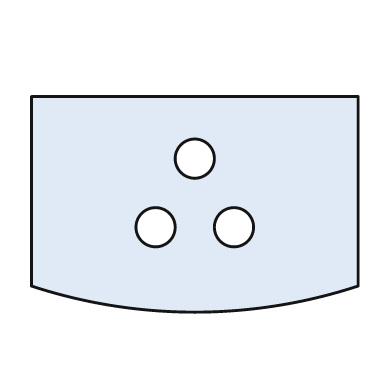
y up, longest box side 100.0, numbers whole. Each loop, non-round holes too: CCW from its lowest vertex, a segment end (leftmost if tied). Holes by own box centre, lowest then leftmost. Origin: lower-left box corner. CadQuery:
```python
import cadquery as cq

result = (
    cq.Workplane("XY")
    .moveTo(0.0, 8.0)
    .threePointArc((50.0, 0.0), (100.0, 8.0))
    .lineTo(100.0, 66.0)
    .lineTo(0.0, 66.0)
    .close()
    .moveTo(38.0, 26.0)
    .circle(6.0)
    .moveTo(62.0, 26.0)
    .circle(6.0)
    .moveTo(50.0, 47.0)
    .circle(6.0)
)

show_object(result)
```